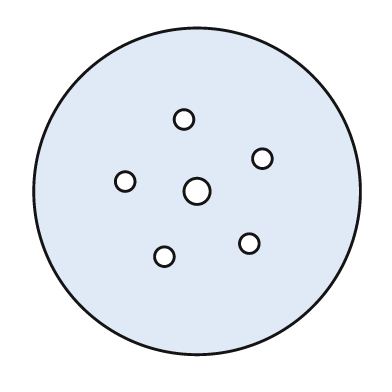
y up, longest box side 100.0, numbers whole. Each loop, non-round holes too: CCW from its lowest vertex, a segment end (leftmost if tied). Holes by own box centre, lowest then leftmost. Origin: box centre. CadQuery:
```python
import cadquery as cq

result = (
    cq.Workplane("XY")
    .moveTo(0.0, 0.0)
    .circle(50.0)
    .moveTo(-10.0, -20.0)
    .circle(3.0)
    .moveTo(16.0, -16.0)
    .circle(3.0)
    .moveTo(0.0, 0.0)
    .circle(4.0)
    .moveTo(-22.0, 3.0)
    .circle(3.0)
    .moveTo(20.0, 10.0)
    .circle(3.0)
    .moveTo(-4.0, 22.0)
    .circle(3.0)
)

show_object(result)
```